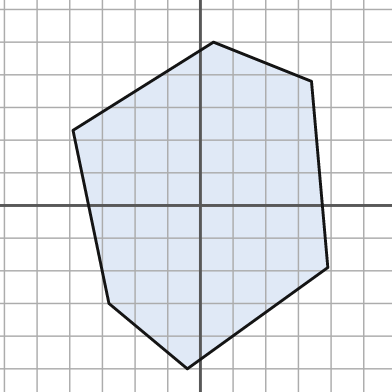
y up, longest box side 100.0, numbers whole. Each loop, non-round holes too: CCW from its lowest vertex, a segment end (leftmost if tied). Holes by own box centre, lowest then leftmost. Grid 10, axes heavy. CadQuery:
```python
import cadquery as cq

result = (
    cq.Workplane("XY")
    .moveTo(-4.0, -50.0)
    .lineTo(39.0, -19.0)
    .lineTo(34.0, 38.0)
    .lineTo(4.0, 50.0)
    .lineTo(-39.0, 23.0)
    .lineTo(-28.0, -30.0)
    .close()
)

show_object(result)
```